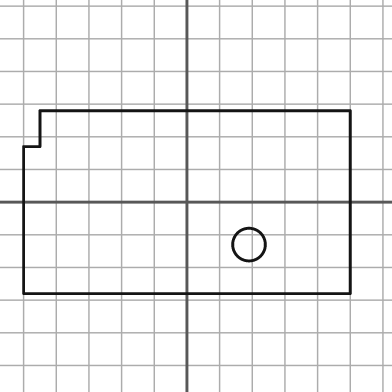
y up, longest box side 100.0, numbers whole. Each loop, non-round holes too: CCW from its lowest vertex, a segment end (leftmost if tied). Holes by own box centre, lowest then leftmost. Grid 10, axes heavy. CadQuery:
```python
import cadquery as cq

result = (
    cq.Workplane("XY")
    .moveTo(-50.0, -28.0)
    .lineTo(50.0, -28.0)
    .lineTo(50.0, 28.0)
    .lineTo(-45.0, 28.0)
    .lineTo(-45.0, 17.0)
    .lineTo(-50.0, 17.0)
    .close()
    .moveTo(19.0, -13.0)
    .circle(5.0)
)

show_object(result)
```